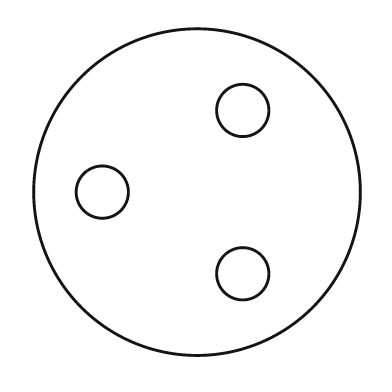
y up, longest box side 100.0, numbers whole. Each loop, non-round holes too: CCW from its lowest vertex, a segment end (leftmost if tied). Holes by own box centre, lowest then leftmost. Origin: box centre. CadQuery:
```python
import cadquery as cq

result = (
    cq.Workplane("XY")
    .moveTo(0.0, 0.0)
    .circle(50.0)
    .moveTo(14.0, -25.0)
    .circle(8.0)
    .moveTo(-29.0, 0.0)
    .circle(8.0)
    .moveTo(14.0, 25.0)
    .circle(8.0)
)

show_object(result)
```